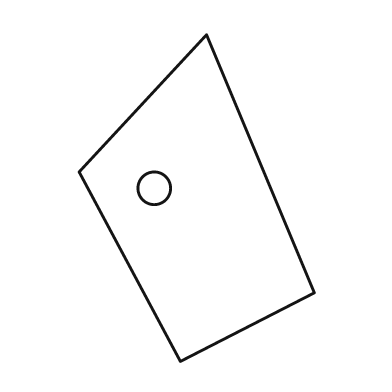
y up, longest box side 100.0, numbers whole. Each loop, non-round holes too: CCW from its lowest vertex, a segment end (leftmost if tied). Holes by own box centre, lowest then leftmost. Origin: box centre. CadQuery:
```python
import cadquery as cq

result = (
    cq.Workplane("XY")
    .moveTo(-5.0, -50.0)
    .lineTo(36.0, -29.0)
    .lineTo(3.0, 50.0)
    .lineTo(-36.0, 8.0)
    .close()
    .moveTo(-13.0, 3.0)
    .circle(5.0)
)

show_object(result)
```